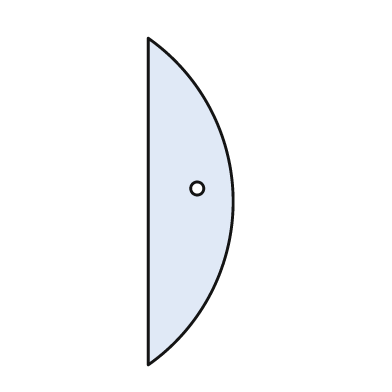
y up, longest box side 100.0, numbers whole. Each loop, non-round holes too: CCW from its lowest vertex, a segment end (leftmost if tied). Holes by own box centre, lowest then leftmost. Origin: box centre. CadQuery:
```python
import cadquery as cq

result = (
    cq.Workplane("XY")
    .moveTo(-13.0, -50.0)
    .threePointArc((13.0, 0.0), (-13.0, 50.0))
    .close()
    .moveTo(2.0, 4.0)
    .circle(2.0)
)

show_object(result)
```